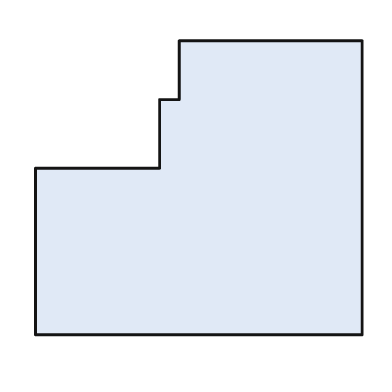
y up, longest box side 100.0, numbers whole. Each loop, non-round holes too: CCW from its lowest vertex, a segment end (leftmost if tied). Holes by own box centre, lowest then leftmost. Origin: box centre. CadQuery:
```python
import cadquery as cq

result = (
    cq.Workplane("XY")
    .moveTo(-50.0, -45.0)
    .lineTo(50.0, -45.0)
    .lineTo(50.0, 45.0)
    .lineTo(-6.0, 45.0)
    .lineTo(-6.0, 27.0)
    .lineTo(-12.0, 27.0)
    .lineTo(-12.0, 6.0)
    .lineTo(-50.0, 6.0)
    .close()
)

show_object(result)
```